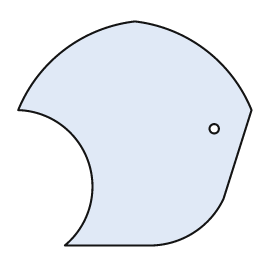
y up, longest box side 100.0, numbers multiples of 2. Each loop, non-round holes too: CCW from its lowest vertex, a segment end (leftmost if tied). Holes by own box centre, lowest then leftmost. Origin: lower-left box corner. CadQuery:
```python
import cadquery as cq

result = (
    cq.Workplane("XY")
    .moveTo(20.0, 0.0)
    .lineTo(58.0, 0.0)
    .threePointArc((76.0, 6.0), (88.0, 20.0))
    .lineTo(100.0, 58.0)
    .threePointArc((80.0, 84.0), (50.0, 96.0))
    .threePointArc((20.0, 84.0), (0.0, 58.0))
    .threePointArc((30.0, 36.0), (20.0, 0.0))
    .close()
    .moveTo(84.0, 50.0)
    .circle(2.0)
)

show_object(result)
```